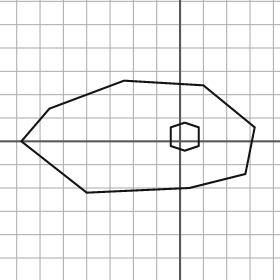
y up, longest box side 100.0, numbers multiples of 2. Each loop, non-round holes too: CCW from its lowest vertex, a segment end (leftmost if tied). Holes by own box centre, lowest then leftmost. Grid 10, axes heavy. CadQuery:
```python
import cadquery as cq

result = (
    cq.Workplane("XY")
    .moveTo(-40.0, -22.0)
    .lineTo(4.0, -20.0)
    .lineTo(28.0, -14.0)
    .lineTo(32.0, 6.0)
    .lineTo(10.0, 24.0)
    .lineTo(-24.0, 26.0)
    .lineTo(-56.0, 14.0)
    .lineTo(-68.0, 0.0)
    .close()
    .moveTo(2.0, -4.0)
    .lineTo(8.0, -2.0)
    .lineTo(8.0, 6.0)
    .lineTo(2.0, 8.0)
    .lineTo(-4.0, 6.0)
    .lineTo(-4.0, -2.0)
    .close()
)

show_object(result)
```